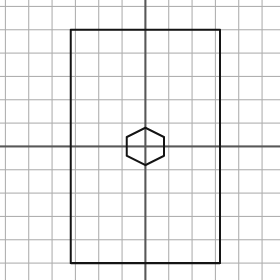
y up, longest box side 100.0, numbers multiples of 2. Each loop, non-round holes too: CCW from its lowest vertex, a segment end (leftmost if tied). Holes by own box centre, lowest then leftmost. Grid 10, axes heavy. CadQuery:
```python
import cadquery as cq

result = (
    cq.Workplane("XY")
    .moveTo(-32.0, -50.0)
    .lineTo(32.0, -50.0)
    .lineTo(32.0, 50.0)
    .lineTo(-32.0, 50.0)
    .close()
    .moveTo(0.0, -8.0)
    .lineTo(8.0, -4.0)
    .lineTo(8.0, 4.0)
    .lineTo(0.0, 8.0)
    .lineTo(-8.0, 4.0)
    .lineTo(-8.0, -4.0)
    .close()
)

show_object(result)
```